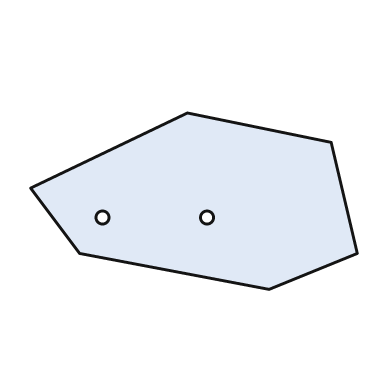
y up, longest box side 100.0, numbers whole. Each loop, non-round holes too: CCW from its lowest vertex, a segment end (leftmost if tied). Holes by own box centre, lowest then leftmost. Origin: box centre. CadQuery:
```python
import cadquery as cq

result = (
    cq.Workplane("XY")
    .moveTo(23.0, -27.0)
    .lineTo(50.0, -16.0)
    .lineTo(42.0, 18.0)
    .lineTo(-2.0, 27.0)
    .lineTo(-50.0, 4.0)
    .lineTo(-35.0, -16.0)
    .close()
    .moveTo(-28.0, -5.0)
    .circle(2.0)
    .moveTo(4.0, -5.0)
    .circle(2.0)
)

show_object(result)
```